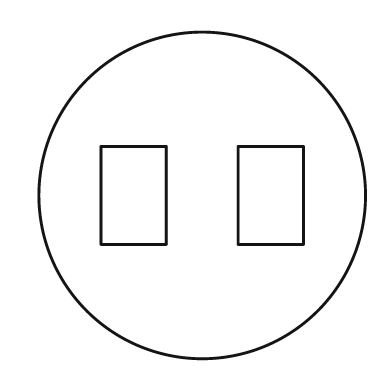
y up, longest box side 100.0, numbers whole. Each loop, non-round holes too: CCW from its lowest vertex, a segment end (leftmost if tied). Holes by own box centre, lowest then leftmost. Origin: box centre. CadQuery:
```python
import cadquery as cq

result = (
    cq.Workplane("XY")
    .moveTo(0.0, 0.0)
    .circle(50.0)
    .moveTo(-31.0, -15.0)
    .lineTo(-11.0, -15.0)
    .lineTo(-11.0, 15.0)
    .lineTo(-31.0, 15.0)
    .close()
    .moveTo(11.0, -15.0)
    .lineTo(31.0, -15.0)
    .lineTo(31.0, 15.0)
    .lineTo(11.0, 15.0)
    .close()
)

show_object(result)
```